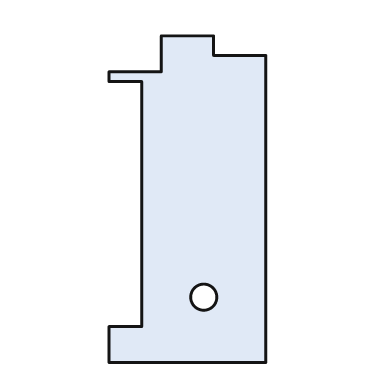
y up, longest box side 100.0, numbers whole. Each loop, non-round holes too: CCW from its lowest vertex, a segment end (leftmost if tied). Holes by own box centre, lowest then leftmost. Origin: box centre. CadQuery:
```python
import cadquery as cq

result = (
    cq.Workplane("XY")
    .moveTo(-24.0, -50.0)
    .lineTo(24.0, -50.0)
    .lineTo(24.0, 44.0)
    .lineTo(8.0, 44.0)
    .lineTo(8.0, 50.0)
    .lineTo(-8.0, 50.0)
    .lineTo(-8.0, 39.0)
    .lineTo(-24.0, 39.0)
    .lineTo(-24.0, 36.0)
    .lineTo(-14.0, 36.0)
    .lineTo(-14.0, -39.0)
    .lineTo(-24.0, -39.0)
    .close()
    .moveTo(5.0, -30.0)
    .circle(4.0)
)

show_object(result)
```